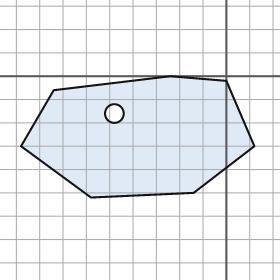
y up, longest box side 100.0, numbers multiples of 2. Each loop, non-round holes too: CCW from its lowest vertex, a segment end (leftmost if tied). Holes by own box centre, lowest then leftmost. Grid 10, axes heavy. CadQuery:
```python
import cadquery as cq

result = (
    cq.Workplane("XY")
    .moveTo(-58.0, -52.0)
    .lineTo(-14.0, -50.0)
    .lineTo(12.0, -30.0)
    .lineTo(0.0, -2.0)
    .lineTo(-24.0, 0.0)
    .lineTo(-74.0, -6.0)
    .lineTo(-88.0, -30.0)
    .close()
    .moveTo(-48.0, -16.0)
    .circle(4.0)
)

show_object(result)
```